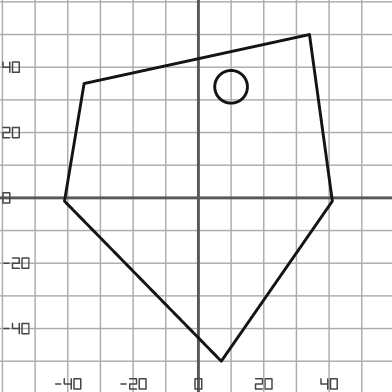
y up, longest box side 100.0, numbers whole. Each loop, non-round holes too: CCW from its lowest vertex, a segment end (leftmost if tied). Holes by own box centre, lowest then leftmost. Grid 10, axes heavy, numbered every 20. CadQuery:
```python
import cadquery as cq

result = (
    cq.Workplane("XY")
    .moveTo(7.0, -50.0)
    .lineTo(41.0, -1.0)
    .lineTo(34.0, 50.0)
    .lineTo(-35.0, 35.0)
    .lineTo(-41.0, -1.0)
    .close()
    .moveTo(10.0, 34.0)
    .circle(5.0)
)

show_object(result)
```